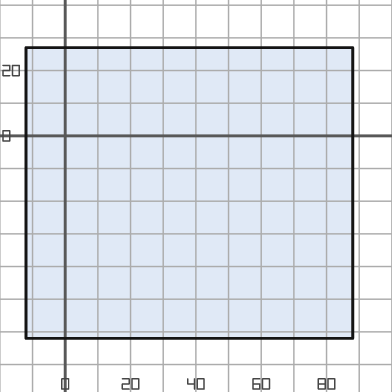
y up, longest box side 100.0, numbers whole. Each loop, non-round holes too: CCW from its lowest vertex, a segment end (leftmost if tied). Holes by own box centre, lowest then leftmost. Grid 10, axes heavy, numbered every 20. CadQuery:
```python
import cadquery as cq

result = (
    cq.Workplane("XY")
    .moveTo(-12.0, -62.0)
    .lineTo(88.0, -62.0)
    .lineTo(88.0, 27.0)
    .lineTo(-12.0, 27.0)
    .close()
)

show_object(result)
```